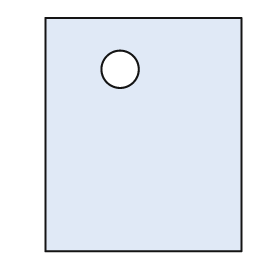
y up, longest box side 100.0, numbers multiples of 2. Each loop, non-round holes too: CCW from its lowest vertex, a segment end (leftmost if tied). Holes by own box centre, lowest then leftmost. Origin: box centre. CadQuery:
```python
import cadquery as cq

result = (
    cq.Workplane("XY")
    .moveTo(-42.0, -50.0)
    .lineTo(42.0, -50.0)
    .lineTo(42.0, 50.0)
    .lineTo(-42.0, 50.0)
    .close()
    .moveTo(-10.0, 28.0)
    .circle(8.0)
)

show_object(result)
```